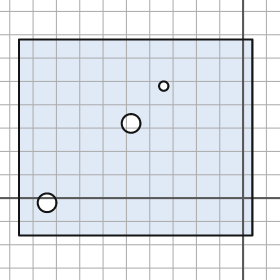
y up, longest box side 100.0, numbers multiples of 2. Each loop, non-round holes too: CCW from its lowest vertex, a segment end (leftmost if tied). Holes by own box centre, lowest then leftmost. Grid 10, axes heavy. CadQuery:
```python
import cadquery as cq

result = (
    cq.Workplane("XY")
    .moveTo(-96.0, -16.0)
    .lineTo(4.0, -16.0)
    .lineTo(4.0, 68.0)
    .lineTo(-96.0, 68.0)
    .close()
    .moveTo(-84.0, -2.0)
    .circle(4.0)
    .moveTo(-48.0, 32.0)
    .circle(4.0)
    .moveTo(-34.0, 48.0)
    .circle(2.0)
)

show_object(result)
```